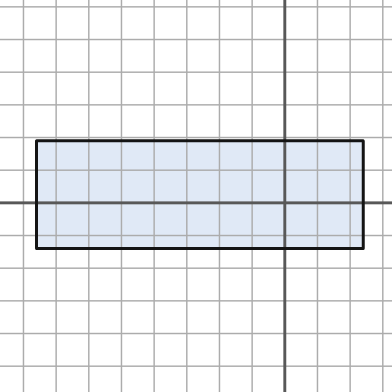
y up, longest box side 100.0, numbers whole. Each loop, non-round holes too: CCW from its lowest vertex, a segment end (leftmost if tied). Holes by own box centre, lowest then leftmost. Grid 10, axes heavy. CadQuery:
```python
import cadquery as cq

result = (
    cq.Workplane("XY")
    .moveTo(-76.0, -14.0)
    .lineTo(24.0, -14.0)
    .lineTo(24.0, 19.0)
    .lineTo(-76.0, 19.0)
    .close()
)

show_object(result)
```